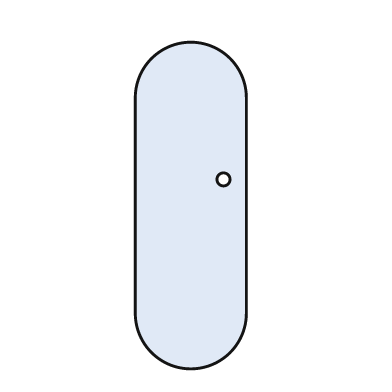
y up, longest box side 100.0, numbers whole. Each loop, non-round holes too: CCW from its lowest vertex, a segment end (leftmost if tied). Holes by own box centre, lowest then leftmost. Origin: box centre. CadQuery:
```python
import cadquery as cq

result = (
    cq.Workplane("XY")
    .moveTo(-17.0, -33.0)
    .threePointArc((0.0, -50.0), (17.0, -33.0))
    .lineTo(17.0, 33.0)
    .threePointArc((0.0, 50.0), (-17.0, 33.0))
    .close()
    .moveTo(10.0, 8.0)
    .circle(2.0)
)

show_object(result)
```